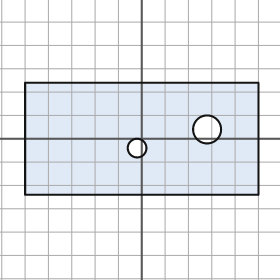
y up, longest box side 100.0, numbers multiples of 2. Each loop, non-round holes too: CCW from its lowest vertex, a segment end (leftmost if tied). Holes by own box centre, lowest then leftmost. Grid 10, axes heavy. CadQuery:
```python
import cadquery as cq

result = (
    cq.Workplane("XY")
    .moveTo(-50.0, -24.0)
    .lineTo(50.0, -24.0)
    .lineTo(50.0, 24.0)
    .lineTo(-50.0, 24.0)
    .close()
    .moveTo(-2.0, -4.0)
    .circle(4.0)
    .moveTo(28.0, 4.0)
    .circle(6.0)
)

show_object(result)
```